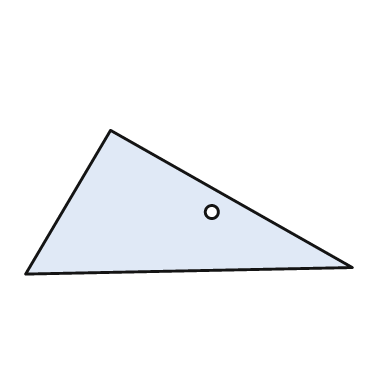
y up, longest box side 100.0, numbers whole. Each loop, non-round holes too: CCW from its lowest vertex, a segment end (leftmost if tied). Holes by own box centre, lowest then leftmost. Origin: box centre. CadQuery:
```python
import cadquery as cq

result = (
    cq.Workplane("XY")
    .moveTo(-50.0, -22.0)
    .lineTo(50.0, -20.0)
    .lineTo(-24.0, 22.0)
    .close()
    .moveTo(7.0, -3.0)
    .circle(2.0)
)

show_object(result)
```